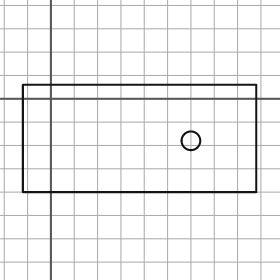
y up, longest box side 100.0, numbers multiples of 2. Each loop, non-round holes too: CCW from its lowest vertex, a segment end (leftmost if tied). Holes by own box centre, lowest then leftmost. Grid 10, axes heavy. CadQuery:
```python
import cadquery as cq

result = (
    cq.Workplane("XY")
    .moveTo(-12.0, -40.0)
    .lineTo(88.0, -40.0)
    .lineTo(88.0, 6.0)
    .lineTo(-12.0, 6.0)
    .close()
    .moveTo(60.0, -18.0)
    .circle(4.0)
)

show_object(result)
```